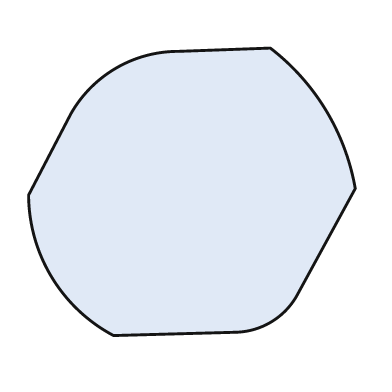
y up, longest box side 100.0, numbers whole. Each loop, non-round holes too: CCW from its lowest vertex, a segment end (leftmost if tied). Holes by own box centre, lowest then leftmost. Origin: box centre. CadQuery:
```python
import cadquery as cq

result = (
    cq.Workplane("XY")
    .moveTo(-24.0, -44.0)
    .lineTo(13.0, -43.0)
    .threePointArc((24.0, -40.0), (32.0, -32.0))
    .lineTo(50.0, 1.0)
    .threePointArc((41.0, 25.0), (24.0, 44.0))
    .lineTo(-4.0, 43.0)
    .threePointArc((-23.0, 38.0), (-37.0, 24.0))
    .lineTo(-50.0, -1.0)
    .threePointArc((-43.0, -26.0), (-24.0, -44.0))
    .close()
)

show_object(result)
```